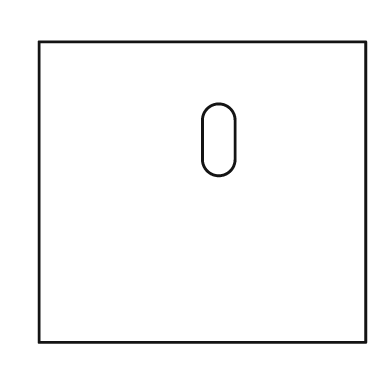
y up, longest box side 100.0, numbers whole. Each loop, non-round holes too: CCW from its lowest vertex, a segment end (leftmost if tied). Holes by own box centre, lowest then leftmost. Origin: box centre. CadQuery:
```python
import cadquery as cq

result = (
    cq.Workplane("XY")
    .moveTo(-50.0, -46.0)
    .lineTo(50.0, -46.0)
    .lineTo(50.0, 46.0)
    .lineTo(-50.0, 46.0)
    .close()
    .moveTo(0.0, 10.0)
    .threePointArc((5.0, 5.0), (10.0, 10.0))
    .lineTo(10.0, 22.0)
    .threePointArc((5.0, 27.0), (0.0, 22.0))
    .close()
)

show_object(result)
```